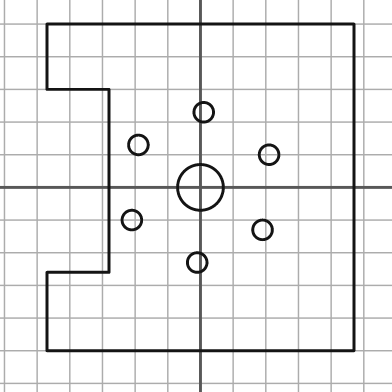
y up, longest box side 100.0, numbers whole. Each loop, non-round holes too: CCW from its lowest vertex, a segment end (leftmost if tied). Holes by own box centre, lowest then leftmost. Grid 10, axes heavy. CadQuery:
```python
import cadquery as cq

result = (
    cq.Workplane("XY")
    .moveTo(-47.0, -50.0)
    .lineTo(47.0, -50.0)
    .lineTo(47.0, 50.0)
    .lineTo(-47.0, 50.0)
    .lineTo(-47.0, 30.0)
    .lineTo(-28.0, 30.0)
    .lineTo(-28.0, -26.0)
    .lineTo(-47.0, -26.0)
    .close()
    .moveTo(-1.0, -23.0)
    .circle(3.0)
    .moveTo(19.0, -13.0)
    .circle(3.0)
    .moveTo(-21.0, -10.0)
    .circle(3.0)
    .moveTo(0.0, 0.0)
    .circle(7.0)
    .moveTo(21.0, 10.0)
    .circle(3.0)
    .moveTo(-19.0, 13.0)
    .circle(3.0)
    .moveTo(1.0, 23.0)
    .circle(3.0)
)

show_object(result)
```